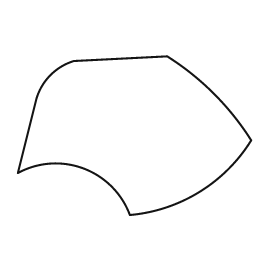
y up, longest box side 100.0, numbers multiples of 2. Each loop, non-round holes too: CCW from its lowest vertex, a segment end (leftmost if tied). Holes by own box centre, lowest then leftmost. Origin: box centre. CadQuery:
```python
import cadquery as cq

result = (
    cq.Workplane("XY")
    .moveTo(-2.0, -34.0)
    .threePointArc((28.0, -24.0), (50.0, -2.0))
    .threePointArc((34.0, 18.0), (14.0, 34.0))
    .lineTo(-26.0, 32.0)
    .threePointArc((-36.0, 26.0), (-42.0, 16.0))
    .lineTo(-50.0, -16.0)
    .threePointArc((-22.0, -14.0), (-2.0, -34.0))
    .close()
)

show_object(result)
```